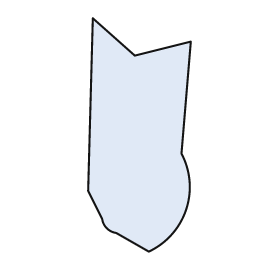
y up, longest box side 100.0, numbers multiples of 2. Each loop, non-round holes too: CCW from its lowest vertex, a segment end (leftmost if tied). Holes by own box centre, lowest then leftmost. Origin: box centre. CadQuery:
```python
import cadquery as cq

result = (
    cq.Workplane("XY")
    .moveTo(4.0, -50.0)
    .threePointArc((20.0, -32.0), (18.0, -8.0))
    .lineTo(22.0, 40.0)
    .lineTo(-2.0, 34.0)
    .lineTo(-20.0, 50.0)
    .lineTo(-22.0, -24.0)
    .lineTo(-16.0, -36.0)
    .threePointArc((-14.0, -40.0), (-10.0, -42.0))
    .close()
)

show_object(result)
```